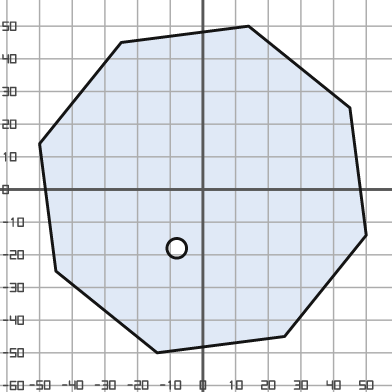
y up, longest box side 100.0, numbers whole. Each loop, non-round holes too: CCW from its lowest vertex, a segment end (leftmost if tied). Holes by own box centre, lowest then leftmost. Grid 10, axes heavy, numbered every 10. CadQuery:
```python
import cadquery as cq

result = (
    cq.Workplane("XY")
    .moveTo(-14.0, -50.0)
    .lineTo(25.0, -45.0)
    .lineTo(50.0, -14.0)
    .lineTo(45.0, 25.0)
    .lineTo(14.0, 50.0)
    .lineTo(-25.0, 45.0)
    .lineTo(-50.0, 14.0)
    .lineTo(-45.0, -25.0)
    .close()
    .moveTo(-8.0, -18.0)
    .circle(3.0)
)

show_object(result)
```